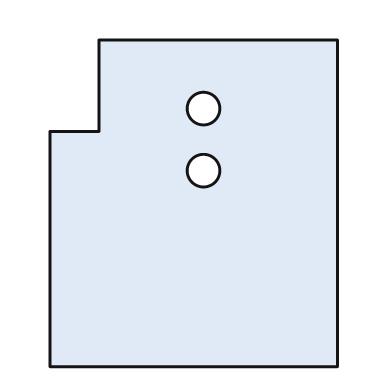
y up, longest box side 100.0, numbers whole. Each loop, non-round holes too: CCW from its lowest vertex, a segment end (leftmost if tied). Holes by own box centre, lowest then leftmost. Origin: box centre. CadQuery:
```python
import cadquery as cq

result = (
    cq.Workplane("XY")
    .moveTo(-44.0, -50.0)
    .lineTo(44.0, -50.0)
    .lineTo(44.0, 50.0)
    .lineTo(-29.0, 50.0)
    .lineTo(-29.0, 22.0)
    .lineTo(-44.0, 22.0)
    .close()
    .moveTo(3.0, 10.0)
    .circle(5.0)
    .moveTo(3.0, 29.0)
    .circle(5.0)
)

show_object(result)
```